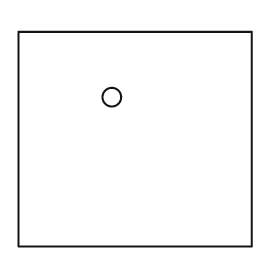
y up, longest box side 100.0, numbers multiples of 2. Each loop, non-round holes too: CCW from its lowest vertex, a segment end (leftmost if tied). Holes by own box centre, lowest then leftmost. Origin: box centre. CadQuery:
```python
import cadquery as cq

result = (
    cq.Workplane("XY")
    .moveTo(-50.0, -46.0)
    .lineTo(50.0, -46.0)
    .lineTo(50.0, 46.0)
    .lineTo(-50.0, 46.0)
    .close()
    .moveTo(-10.0, 18.0)
    .circle(4.0)
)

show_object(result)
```